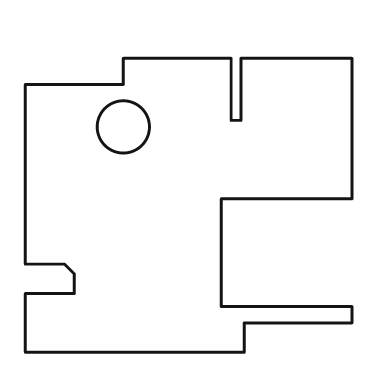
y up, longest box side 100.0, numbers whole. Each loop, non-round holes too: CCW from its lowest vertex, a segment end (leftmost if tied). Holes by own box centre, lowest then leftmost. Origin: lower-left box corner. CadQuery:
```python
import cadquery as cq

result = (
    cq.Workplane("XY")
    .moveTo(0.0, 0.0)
    .lineTo(67.0, 0.0)
    .lineTo(67.0, 9.0)
    .lineTo(100.0, 9.0)
    .lineTo(100.0, 14.0)
    .lineTo(60.0, 14.0)
    .lineTo(60.0, 47.0)
    .lineTo(100.0, 47.0)
    .lineTo(100.0, 90.0)
    .lineTo(66.0, 90.0)
    .lineTo(66.0, 71.0)
    .lineTo(63.0, 71.0)
    .lineTo(63.0, 90.0)
    .lineTo(30.0, 90.0)
    .lineTo(30.0, 82.0)
    .lineTo(0.0, 82.0)
    .lineTo(0.0, 27.0)
    .lineTo(12.0, 27.0)
    .lineTo(15.0, 24.0)
    .lineTo(15.0, 18.0)
    .lineTo(0.0, 18.0)
    .close()
    .moveTo(30.0, 69.0)
    .circle(8.0)
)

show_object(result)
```